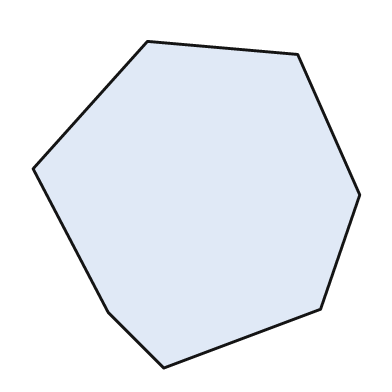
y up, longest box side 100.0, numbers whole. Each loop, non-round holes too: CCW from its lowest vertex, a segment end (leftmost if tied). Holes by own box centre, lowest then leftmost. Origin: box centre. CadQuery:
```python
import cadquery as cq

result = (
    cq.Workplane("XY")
    .moveTo(-10.0, -50.0)
    .lineTo(38.0, -32.0)
    .lineTo(50.0, 3.0)
    .lineTo(31.0, 46.0)
    .lineTo(-15.0, 50.0)
    .lineTo(-50.0, 11.0)
    .lineTo(-27.0, -33.0)
    .close()
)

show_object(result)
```